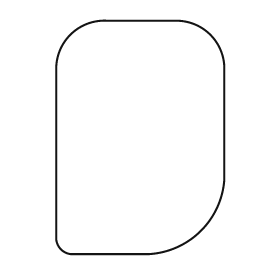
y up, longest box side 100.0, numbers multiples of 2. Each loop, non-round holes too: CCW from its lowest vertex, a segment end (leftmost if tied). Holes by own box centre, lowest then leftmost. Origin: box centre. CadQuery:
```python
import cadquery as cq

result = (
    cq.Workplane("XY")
    .moveTo(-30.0, -50.0)
    .lineTo(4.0, -50.0)
    .threePointArc((26.0, -40.0), (36.0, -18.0))
    .lineTo(36.0, 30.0)
    .threePointArc((30.0, 44.0), (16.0, 50.0))
    .lineTo(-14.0, 50.0)
    .threePointArc((-30.0, 44.0), (-36.0, 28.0))
    .lineTo(-36.0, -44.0)
    .threePointArc((-34.0, -48.0), (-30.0, -50.0))
    .close()
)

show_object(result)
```